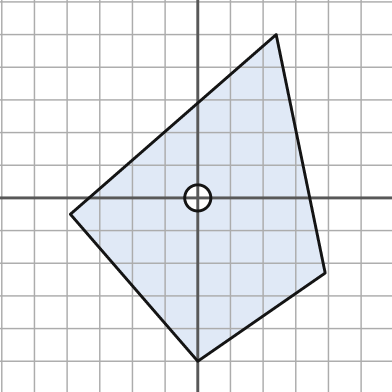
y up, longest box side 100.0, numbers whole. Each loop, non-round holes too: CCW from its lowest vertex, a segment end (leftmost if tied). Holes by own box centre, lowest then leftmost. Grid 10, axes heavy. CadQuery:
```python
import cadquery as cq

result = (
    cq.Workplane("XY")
    .moveTo(0.0, -50.0)
    .lineTo(39.0, -23.0)
    .lineTo(24.0, 50.0)
    .lineTo(-39.0, -5.0)
    .close()
    .moveTo(0.0, 0.0)
    .circle(4.0)
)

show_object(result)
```